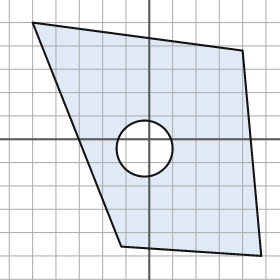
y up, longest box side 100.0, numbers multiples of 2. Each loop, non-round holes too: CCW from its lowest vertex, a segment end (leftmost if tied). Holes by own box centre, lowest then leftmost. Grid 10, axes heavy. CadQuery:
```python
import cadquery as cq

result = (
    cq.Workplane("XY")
    .moveTo(48.0, -50.0)
    .lineTo(40.0, 38.0)
    .lineTo(-50.0, 50.0)
    .lineTo(-12.0, -46.0)
    .close()
    .moveTo(-2.0, -4.0)
    .circle(12.0)
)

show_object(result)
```